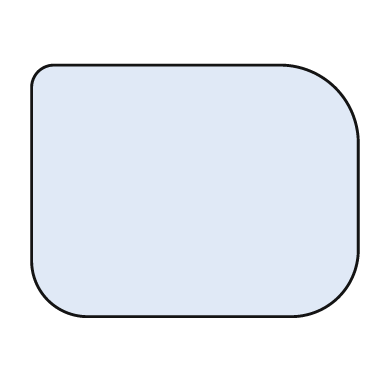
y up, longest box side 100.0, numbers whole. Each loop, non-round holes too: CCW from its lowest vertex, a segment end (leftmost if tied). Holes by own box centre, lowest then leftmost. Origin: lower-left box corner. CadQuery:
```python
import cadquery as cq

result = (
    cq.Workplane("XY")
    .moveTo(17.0, 0.0)
    .lineTo(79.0, 0.0)
    .threePointArc((94.0, 6.0), (100.0, 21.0))
    .lineTo(100.0, 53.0)
    .threePointArc((93.0, 70.0), (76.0, 77.0))
    .lineTo(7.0, 77.0)
    .threePointArc((2.0, 75.0), (0.0, 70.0))
    .lineTo(0.0, 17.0)
    .threePointArc((5.0, 5.0), (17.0, 0.0))
    .close()
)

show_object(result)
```